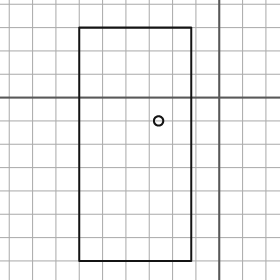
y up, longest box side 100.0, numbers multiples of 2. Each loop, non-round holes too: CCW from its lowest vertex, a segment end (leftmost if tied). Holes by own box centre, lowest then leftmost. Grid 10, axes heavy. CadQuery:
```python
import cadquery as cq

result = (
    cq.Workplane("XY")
    .moveTo(-60.0, -70.0)
    .lineTo(-12.0, -70.0)
    .lineTo(-12.0, 30.0)
    .lineTo(-60.0, 30.0)
    .close()
    .moveTo(-26.0, -10.0)
    .circle(2.0)
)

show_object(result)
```